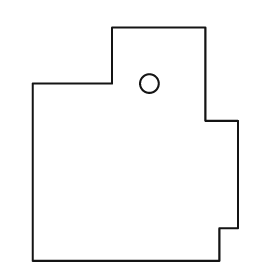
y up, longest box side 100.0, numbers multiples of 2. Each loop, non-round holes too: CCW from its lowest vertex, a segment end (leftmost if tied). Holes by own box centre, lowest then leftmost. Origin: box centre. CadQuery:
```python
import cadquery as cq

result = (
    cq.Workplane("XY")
    .moveTo(-44.0, -50.0)
    .lineTo(36.0, -50.0)
    .lineTo(36.0, -36.0)
    .lineTo(44.0, -36.0)
    .lineTo(44.0, 10.0)
    .lineTo(30.0, 10.0)
    .lineTo(30.0, 50.0)
    .lineTo(-10.0, 50.0)
    .lineTo(-10.0, 26.0)
    .lineTo(-44.0, 26.0)
    .close()
    .moveTo(6.0, 26.0)
    .circle(4.0)
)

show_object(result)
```